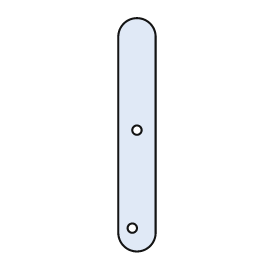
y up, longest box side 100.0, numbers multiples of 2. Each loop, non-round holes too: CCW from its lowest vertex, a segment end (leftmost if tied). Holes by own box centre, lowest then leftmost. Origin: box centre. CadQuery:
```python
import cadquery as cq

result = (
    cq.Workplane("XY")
    .moveTo(-8.0, -42.0)
    .threePointArc((0.0, -50.0), (8.0, -42.0))
    .lineTo(8.0, 42.0)
    .threePointArc((0.0, 50.0), (-8.0, 42.0))
    .close()
    .moveTo(-2.0, -40.0)
    .circle(2.0)
    .moveTo(0.0, 2.0)
    .circle(2.0)
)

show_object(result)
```